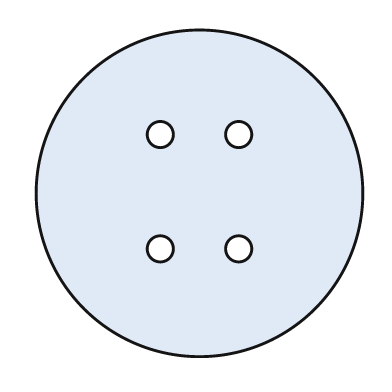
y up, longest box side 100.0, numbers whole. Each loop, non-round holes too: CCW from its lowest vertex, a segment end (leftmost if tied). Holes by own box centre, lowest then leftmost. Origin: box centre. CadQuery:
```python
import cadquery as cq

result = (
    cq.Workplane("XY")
    .moveTo(0.0, 0.0)
    .circle(50.0)
    .moveTo(-12.0, -17.0)
    .circle(4.0)
    .moveTo(12.0, -17.0)
    .circle(4.0)
    .moveTo(-12.0, 18.0)
    .circle(4.0)
    .moveTo(12.0, 18.0)
    .circle(4.0)
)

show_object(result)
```